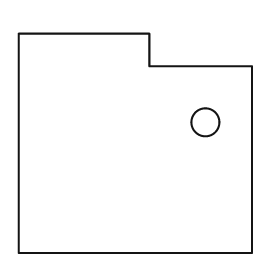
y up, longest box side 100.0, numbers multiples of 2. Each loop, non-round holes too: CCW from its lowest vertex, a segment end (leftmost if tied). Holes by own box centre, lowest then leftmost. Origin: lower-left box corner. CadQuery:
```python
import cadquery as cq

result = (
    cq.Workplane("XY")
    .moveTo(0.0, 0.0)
    .lineTo(100.0, 0.0)
    .lineTo(100.0, 80.0)
    .lineTo(56.0, 80.0)
    .lineTo(56.0, 94.0)
    .lineTo(0.0, 94.0)
    .close()
    .moveTo(80.0, 56.0)
    .circle(6.0)
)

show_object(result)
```